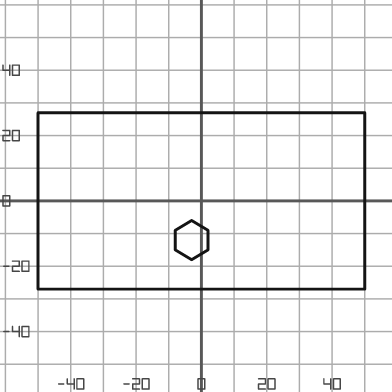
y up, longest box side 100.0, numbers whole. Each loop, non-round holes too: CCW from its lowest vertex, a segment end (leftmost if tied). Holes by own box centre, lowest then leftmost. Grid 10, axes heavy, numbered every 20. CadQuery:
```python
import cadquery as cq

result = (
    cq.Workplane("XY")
    .moveTo(-50.0, -27.0)
    .lineTo(50.0, -27.0)
    .lineTo(50.0, 27.0)
    .lineTo(-50.0, 27.0)
    .close()
    .moveTo(-3.0, -18.0)
    .lineTo(2.0, -15.0)
    .lineTo(2.0, -9.0)
    .lineTo(-3.0, -6.0)
    .lineTo(-8.0, -9.0)
    .lineTo(-8.0, -15.0)
    .close()
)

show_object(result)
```